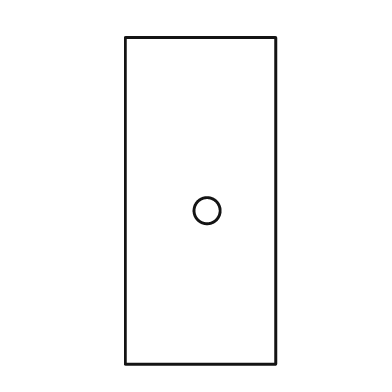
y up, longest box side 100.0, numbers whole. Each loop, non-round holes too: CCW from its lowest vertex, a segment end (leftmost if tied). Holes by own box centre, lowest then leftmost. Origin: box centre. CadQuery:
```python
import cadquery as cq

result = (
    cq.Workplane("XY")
    .moveTo(-23.0, -50.0)
    .lineTo(23.0, -50.0)
    .lineTo(23.0, 50.0)
    .lineTo(-23.0, 50.0)
    .close()
    .moveTo(2.0, -3.0)
    .circle(4.0)
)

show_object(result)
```